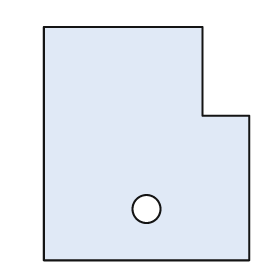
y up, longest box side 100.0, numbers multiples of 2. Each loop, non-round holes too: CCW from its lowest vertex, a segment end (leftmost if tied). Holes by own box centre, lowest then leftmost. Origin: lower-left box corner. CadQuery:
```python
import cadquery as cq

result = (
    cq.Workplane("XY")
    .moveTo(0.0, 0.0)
    .lineTo(88.0, 0.0)
    .lineTo(88.0, 62.0)
    .lineTo(68.0, 62.0)
    .lineTo(68.0, 100.0)
    .lineTo(0.0, 100.0)
    .close()
    .moveTo(44.0, 22.0)
    .circle(6.0)
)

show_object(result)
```